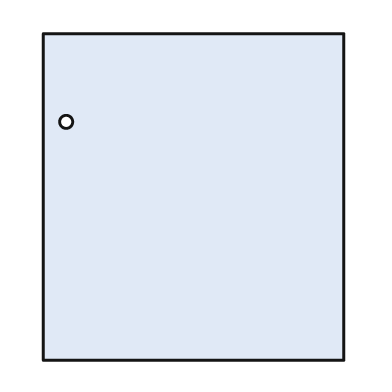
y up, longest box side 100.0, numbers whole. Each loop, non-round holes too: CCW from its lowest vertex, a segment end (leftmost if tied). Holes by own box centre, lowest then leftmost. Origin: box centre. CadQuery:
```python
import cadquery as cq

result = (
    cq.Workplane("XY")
    .moveTo(-46.0, -50.0)
    .lineTo(46.0, -50.0)
    .lineTo(46.0, 50.0)
    .lineTo(-46.0, 50.0)
    .close()
    .moveTo(-39.0, 23.0)
    .circle(2.0)
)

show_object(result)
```